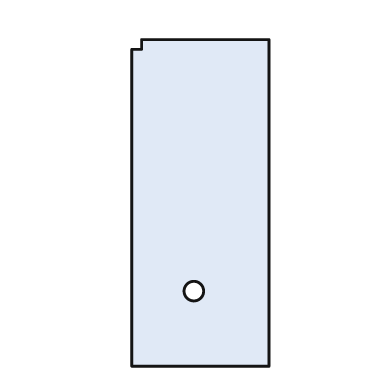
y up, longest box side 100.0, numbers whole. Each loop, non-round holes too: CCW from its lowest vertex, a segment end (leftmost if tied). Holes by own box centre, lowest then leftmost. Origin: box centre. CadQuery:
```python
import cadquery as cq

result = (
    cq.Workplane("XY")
    .moveTo(-21.0, -50.0)
    .lineTo(21.0, -50.0)
    .lineTo(21.0, 50.0)
    .lineTo(-18.0, 50.0)
    .lineTo(-18.0, 47.0)
    .lineTo(-21.0, 47.0)
    .close()
    .moveTo(-2.0, -27.0)
    .circle(3.0)
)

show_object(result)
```